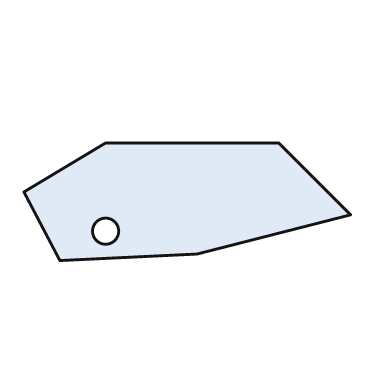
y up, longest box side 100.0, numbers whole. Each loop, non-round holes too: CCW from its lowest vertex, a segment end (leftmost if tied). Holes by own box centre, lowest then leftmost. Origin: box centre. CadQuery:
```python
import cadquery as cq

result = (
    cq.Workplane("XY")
    .moveTo(-39.0, -18.0)
    .lineTo(3.0, -16.0)
    .lineTo(50.0, -4.0)
    .lineTo(28.0, 18.0)
    .lineTo(-25.0, 18.0)
    .lineTo(-50.0, 3.0)
    .close()
    .moveTo(-25.0, -9.0)
    .circle(4.0)
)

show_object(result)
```